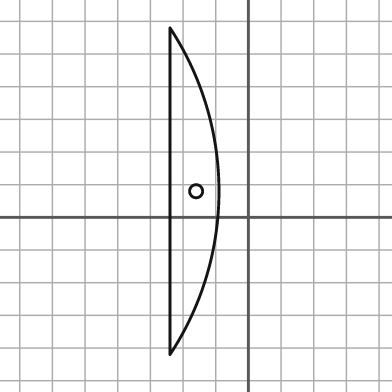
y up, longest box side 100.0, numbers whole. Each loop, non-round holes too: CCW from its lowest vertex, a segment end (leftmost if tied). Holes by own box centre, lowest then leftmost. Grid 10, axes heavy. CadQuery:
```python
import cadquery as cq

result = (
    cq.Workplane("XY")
    .moveTo(-24.0, -42.0)
    .threePointArc((-9.0, 8.0), (-24.0, 58.0))
    .close()
    .moveTo(-16.0, 8.0)
    .circle(2.0)
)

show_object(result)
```